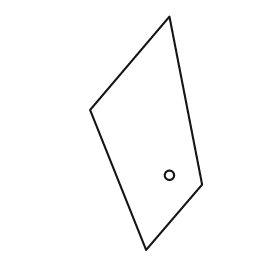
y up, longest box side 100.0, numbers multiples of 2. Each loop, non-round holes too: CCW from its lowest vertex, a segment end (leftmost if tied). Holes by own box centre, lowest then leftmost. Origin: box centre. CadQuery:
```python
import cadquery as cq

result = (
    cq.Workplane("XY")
    .moveTo(0.0, -50.0)
    .lineTo(24.0, -22.0)
    .lineTo(10.0, 50.0)
    .lineTo(-24.0, 10.0)
    .close()
    .moveTo(10.0, -18.0)
    .circle(2.0)
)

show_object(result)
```